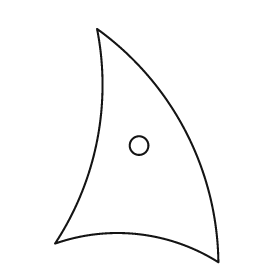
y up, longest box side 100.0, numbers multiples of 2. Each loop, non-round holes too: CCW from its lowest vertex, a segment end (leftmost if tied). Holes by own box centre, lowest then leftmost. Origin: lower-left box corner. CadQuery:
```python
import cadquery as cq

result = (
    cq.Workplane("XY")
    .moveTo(70.0, 0.0)
    .threePointArc((56.0, 56.0), (18.0, 100.0))
    .threePointArc((18.0, 52.0), (0.0, 8.0))
    .threePointArc((36.0, 12.0), (70.0, 0.0))
    .close()
    .moveTo(36.0, 50.0)
    .circle(4.0)
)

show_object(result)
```